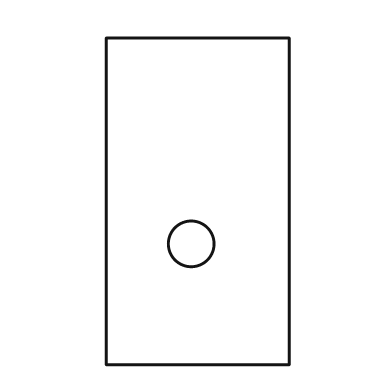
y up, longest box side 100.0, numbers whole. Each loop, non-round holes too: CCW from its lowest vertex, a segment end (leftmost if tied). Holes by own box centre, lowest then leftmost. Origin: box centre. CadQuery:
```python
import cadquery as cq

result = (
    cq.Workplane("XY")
    .moveTo(-28.0, -50.0)
    .lineTo(28.0, -50.0)
    .lineTo(28.0, 50.0)
    .lineTo(-28.0, 50.0)
    .close()
    .moveTo(-2.0, -13.0)
    .circle(7.0)
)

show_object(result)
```